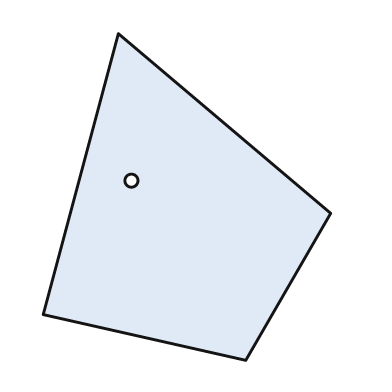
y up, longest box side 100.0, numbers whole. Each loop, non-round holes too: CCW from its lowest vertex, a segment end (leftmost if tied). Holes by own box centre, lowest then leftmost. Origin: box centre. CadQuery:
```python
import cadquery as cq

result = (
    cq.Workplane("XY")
    .moveTo(18.0, -50.0)
    .lineTo(44.0, -5.0)
    .lineTo(-21.0, 50.0)
    .lineTo(-44.0, -36.0)
    .close()
    .moveTo(-17.0, 5.0)
    .circle(2.0)
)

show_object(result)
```